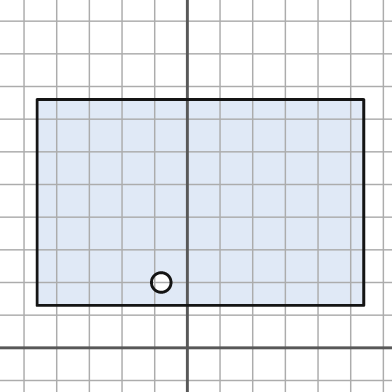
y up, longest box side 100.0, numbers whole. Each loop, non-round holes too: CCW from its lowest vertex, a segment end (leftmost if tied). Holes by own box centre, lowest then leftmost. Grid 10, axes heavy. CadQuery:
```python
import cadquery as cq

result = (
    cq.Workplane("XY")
    .moveTo(-46.0, 13.0)
    .lineTo(54.0, 13.0)
    .lineTo(54.0, 76.0)
    .lineTo(-46.0, 76.0)
    .close()
    .moveTo(-8.0, 20.0)
    .circle(3.0)
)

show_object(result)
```